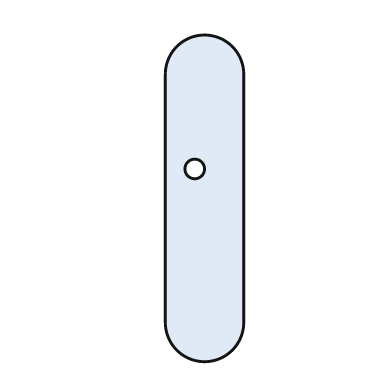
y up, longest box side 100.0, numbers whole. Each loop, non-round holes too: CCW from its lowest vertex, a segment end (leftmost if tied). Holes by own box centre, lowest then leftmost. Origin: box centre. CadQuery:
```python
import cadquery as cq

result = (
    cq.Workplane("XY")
    .moveTo(-12.0, -38.0)
    .threePointArc((0.0, -50.0), (12.0, -38.0))
    .lineTo(12.0, 38.0)
    .threePointArc((0.0, 50.0), (-12.0, 38.0))
    .close()
    .moveTo(-3.0, 9.0)
    .circle(3.0)
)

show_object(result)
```